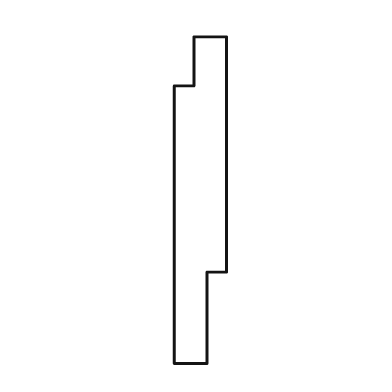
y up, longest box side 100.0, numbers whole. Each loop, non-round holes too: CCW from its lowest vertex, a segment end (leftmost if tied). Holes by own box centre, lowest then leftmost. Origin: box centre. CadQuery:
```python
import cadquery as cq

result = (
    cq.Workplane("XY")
    .moveTo(-8.0, -50.0)
    .lineTo(2.0, -50.0)
    .lineTo(2.0, -22.0)
    .lineTo(8.0, -22.0)
    .lineTo(8.0, 50.0)
    .lineTo(-2.0, 50.0)
    .lineTo(-2.0, 35.0)
    .lineTo(-8.0, 35.0)
    .close()
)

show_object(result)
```